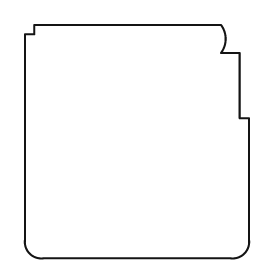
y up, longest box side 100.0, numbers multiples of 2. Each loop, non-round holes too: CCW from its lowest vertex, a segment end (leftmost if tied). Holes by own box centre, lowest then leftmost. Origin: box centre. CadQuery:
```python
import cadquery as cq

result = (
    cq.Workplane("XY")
    .moveTo(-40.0, -50.0)
    .lineTo(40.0, -50.0)
    .threePointArc((46.0, -48.0), (48.0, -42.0))
    .lineTo(48.0, 10.0)
    .lineTo(44.0, 10.0)
    .lineTo(44.0, 38.0)
    .lineTo(36.0, 38.0)
    .threePointArc((38.0, 44.0), (36.0, 50.0))
    .lineTo(-44.0, 50.0)
    .lineTo(-44.0, 46.0)
    .lineTo(-48.0, 46.0)
    .lineTo(-48.0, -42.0)
    .threePointArc((-46.0, -48.0), (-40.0, -50.0))
    .close()
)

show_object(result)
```